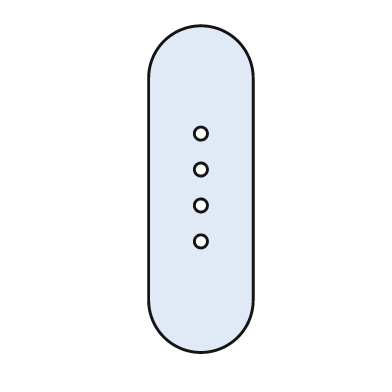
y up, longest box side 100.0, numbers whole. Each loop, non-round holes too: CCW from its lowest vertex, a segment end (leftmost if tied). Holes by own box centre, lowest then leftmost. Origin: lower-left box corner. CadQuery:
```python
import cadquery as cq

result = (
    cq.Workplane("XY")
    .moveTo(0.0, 16.0)
    .threePointArc((16.0, 0.0), (32.0, 16.0))
    .lineTo(32.0, 84.0)
    .threePointArc((16.0, 100.0), (0.0, 84.0))
    .close()
    .moveTo(16.0, 34.0)
    .circle(2.0)
    .moveTo(16.0, 45.0)
    .circle(2.0)
    .moveTo(16.0, 56.0)
    .circle(2.0)
    .moveTo(16.0, 67.0)
    .circle(2.0)
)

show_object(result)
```